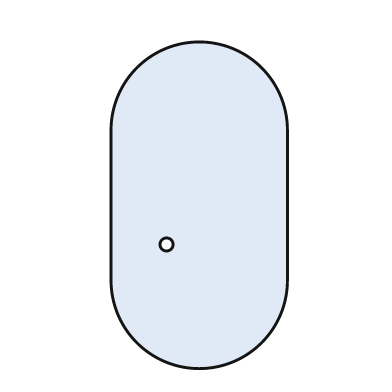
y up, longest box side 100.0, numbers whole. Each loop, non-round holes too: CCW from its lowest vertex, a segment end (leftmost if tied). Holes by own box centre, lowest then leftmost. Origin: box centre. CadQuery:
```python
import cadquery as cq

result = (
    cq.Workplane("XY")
    .moveTo(-27.0, -23.0)
    .threePointArc((0.0, -50.0), (27.0, -23.0))
    .lineTo(27.0, 23.0)
    .threePointArc((0.0, 50.0), (-27.0, 23.0))
    .close()
    .moveTo(-10.0, -12.0)
    .circle(2.0)
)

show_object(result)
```